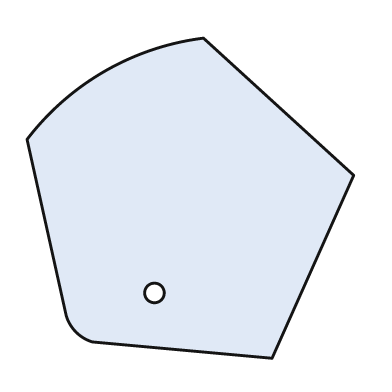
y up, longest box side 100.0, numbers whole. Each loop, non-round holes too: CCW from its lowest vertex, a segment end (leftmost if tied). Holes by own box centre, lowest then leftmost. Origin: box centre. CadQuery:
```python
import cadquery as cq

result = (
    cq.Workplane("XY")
    .moveTo(25.0, -49.0)
    .lineTo(50.0, 7.0)
    .lineTo(4.0, 49.0)
    .threePointArc((-26.0, 39.0), (-50.0, 18.0))
    .lineTo(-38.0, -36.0)
    .threePointArc((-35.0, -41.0), (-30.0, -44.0))
    .close()
    .moveTo(-11.0, -29.0)
    .circle(3.0)
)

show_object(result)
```